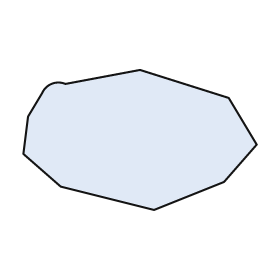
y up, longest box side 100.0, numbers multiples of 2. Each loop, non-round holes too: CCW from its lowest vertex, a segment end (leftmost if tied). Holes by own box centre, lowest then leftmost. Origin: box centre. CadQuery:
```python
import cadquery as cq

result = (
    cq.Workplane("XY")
    .moveTo(6.0, -30.0)
    .lineTo(36.0, -18.0)
    .lineTo(50.0, -2.0)
    .lineTo(38.0, 18.0)
    .lineTo(0.0, 30.0)
    .lineTo(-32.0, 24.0)
    .threePointArc((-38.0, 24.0), (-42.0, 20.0))
    .lineTo(-48.0, 10.0)
    .lineTo(-50.0, -6.0)
    .lineTo(-34.0, -20.0)
    .close()
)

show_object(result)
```